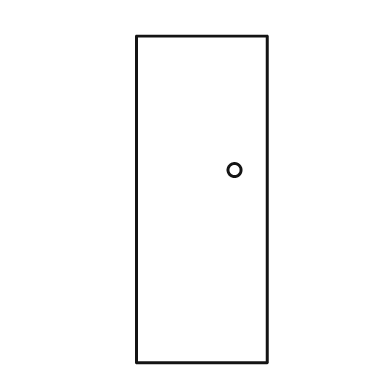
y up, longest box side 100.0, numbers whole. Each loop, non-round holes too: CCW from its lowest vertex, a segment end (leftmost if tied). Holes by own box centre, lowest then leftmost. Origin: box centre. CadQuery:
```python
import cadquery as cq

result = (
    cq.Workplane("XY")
    .moveTo(-20.0, -50.0)
    .lineTo(20.0, -50.0)
    .lineTo(20.0, 50.0)
    .lineTo(-20.0, 50.0)
    .close()
    .moveTo(10.0, 9.0)
    .circle(2.0)
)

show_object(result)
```